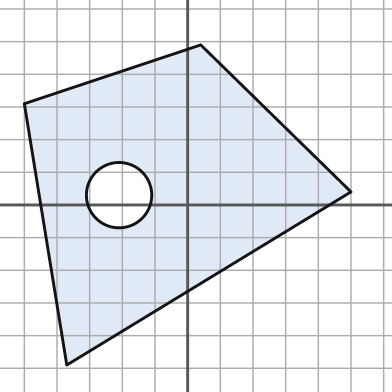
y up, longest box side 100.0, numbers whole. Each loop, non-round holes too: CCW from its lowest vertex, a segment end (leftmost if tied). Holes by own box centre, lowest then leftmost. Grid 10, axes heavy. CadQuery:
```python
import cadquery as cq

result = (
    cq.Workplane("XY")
    .moveTo(-37.0, -49.0)
    .lineTo(50.0, 4.0)
    .lineTo(4.0, 49.0)
    .lineTo(-50.0, 31.0)
    .close()
    .moveTo(-21.0, 3.0)
    .circle(10.0)
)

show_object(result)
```